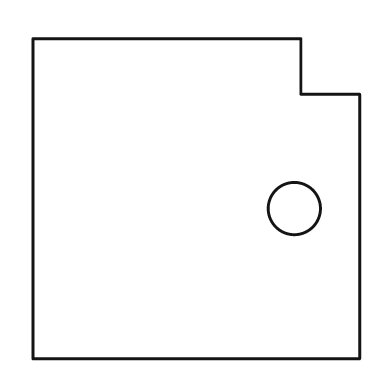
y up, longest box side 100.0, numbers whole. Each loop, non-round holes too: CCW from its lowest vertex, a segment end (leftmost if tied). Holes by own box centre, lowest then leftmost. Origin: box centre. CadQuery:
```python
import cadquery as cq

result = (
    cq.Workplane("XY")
    .moveTo(-50.0, -49.0)
    .lineTo(50.0, -49.0)
    .lineTo(50.0, 32.0)
    .lineTo(32.0, 32.0)
    .lineTo(32.0, 49.0)
    .lineTo(-50.0, 49.0)
    .close()
    .moveTo(30.0, -3.0)
    .circle(8.0)
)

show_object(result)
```